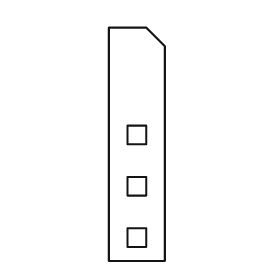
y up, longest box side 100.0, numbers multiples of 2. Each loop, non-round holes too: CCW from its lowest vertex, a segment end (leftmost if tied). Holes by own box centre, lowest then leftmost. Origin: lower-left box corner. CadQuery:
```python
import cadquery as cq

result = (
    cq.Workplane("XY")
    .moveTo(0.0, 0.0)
    .lineTo(24.0, 0.0)
    .lineTo(24.0, 92.0)
    .lineTo(16.0, 100.0)
    .lineTo(0.0, 100.0)
    .close()
    .moveTo(8.0, 6.0)
    .lineTo(16.0, 6.0)
    .lineTo(16.0, 14.0)
    .lineTo(8.0, 14.0)
    .close()
    .moveTo(8.0, 28.0)
    .lineTo(16.0, 28.0)
    .lineTo(16.0, 36.0)
    .lineTo(8.0, 36.0)
    .close()
    .moveTo(8.0, 50.0)
    .lineTo(16.0, 50.0)
    .lineTo(16.0, 58.0)
    .lineTo(8.0, 58.0)
    .close()
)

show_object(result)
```